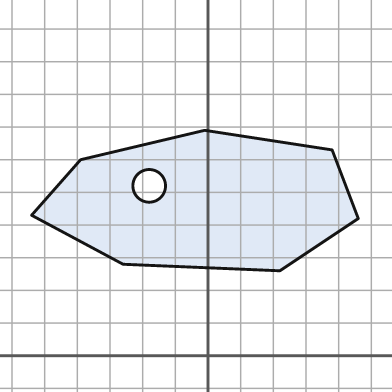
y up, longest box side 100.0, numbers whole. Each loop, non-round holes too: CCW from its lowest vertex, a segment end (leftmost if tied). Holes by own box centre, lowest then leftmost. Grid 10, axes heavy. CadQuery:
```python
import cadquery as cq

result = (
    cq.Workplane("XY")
    .moveTo(22.0, 26.0)
    .lineTo(46.0, 42.0)
    .lineTo(38.0, 63.0)
    .lineTo(-1.0, 69.0)
    .lineTo(-39.0, 60.0)
    .lineTo(-54.0, 43.0)
    .lineTo(-26.0, 28.0)
    .close()
    .moveTo(-18.0, 52.0)
    .circle(5.0)
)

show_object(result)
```